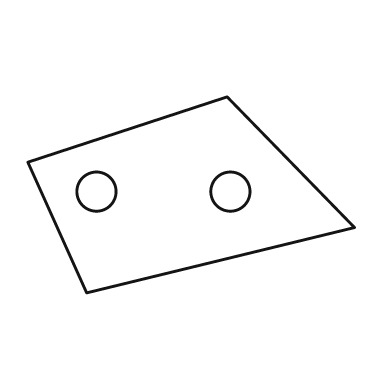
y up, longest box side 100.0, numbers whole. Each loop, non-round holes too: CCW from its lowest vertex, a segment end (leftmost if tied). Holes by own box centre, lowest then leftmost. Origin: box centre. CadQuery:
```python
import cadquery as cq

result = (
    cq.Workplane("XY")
    .moveTo(-32.0, -30.0)
    .lineTo(50.0, -10.0)
    .lineTo(11.0, 30.0)
    .lineTo(-50.0, 10.0)
    .close()
    .moveTo(-29.0, 1.0)
    .circle(6.0)
    .moveTo(12.0, 1.0)
    .circle(6.0)
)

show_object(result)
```